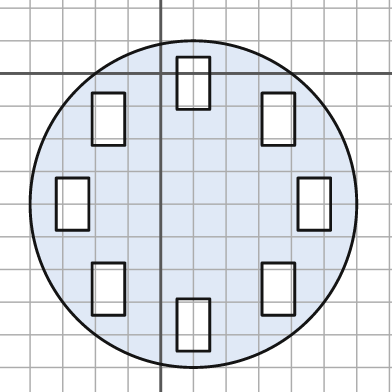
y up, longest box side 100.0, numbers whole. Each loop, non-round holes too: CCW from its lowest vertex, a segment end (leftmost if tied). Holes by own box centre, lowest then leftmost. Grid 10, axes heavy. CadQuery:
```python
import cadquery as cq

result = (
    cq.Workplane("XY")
    .moveTo(10.0, -40.0)
    .circle(50.0)
    .moveTo(5.0, -85.0)
    .lineTo(15.0, -85.0)
    .lineTo(15.0, -69.0)
    .lineTo(5.0, -69.0)
    .close()
    .moveTo(-21.0, -74.0)
    .lineTo(-11.0, -74.0)
    .lineTo(-11.0, -58.0)
    .lineTo(-21.0, -58.0)
    .close()
    .moveTo(31.0, -74.0)
    .lineTo(41.0, -74.0)
    .lineTo(41.0, -58.0)
    .lineTo(31.0, -58.0)
    .close()
    .moveTo(-32.0, -48.0)
    .lineTo(-22.0, -48.0)
    .lineTo(-22.0, -32.0)
    .lineTo(-32.0, -32.0)
    .close()
    .moveTo(42.0, -48.0)
    .lineTo(52.0, -48.0)
    .lineTo(52.0, -32.0)
    .lineTo(42.0, -32.0)
    .close()
    .moveTo(-21.0, -22.0)
    .lineTo(-11.0, -22.0)
    .lineTo(-11.0, -6.0)
    .lineTo(-21.0, -6.0)
    .close()
    .moveTo(31.0, -22.0)
    .lineTo(41.0, -22.0)
    .lineTo(41.0, -6.0)
    .lineTo(31.0, -6.0)
    .close()
    .moveTo(5.0, -11.0)
    .lineTo(15.0, -11.0)
    .lineTo(15.0, 5.0)
    .lineTo(5.0, 5.0)
    .close()
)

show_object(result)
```